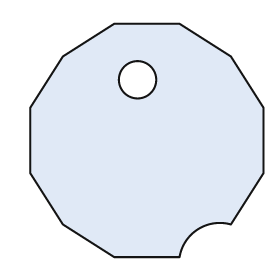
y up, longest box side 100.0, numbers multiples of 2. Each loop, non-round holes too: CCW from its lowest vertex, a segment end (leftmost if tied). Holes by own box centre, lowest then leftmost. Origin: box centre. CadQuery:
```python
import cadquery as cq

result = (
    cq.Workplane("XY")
    .moveTo(-14.0, -50.0)
    .lineTo(14.0, -50.0)
    .threePointArc((22.0, -38.0), (36.0, -36.0))
    .lineTo(50.0, -14.0)
    .lineTo(50.0, 14.0)
    .lineTo(36.0, 36.0)
    .lineTo(14.0, 50.0)
    .lineTo(-14.0, 50.0)
    .lineTo(-36.0, 36.0)
    .lineTo(-50.0, 14.0)
    .lineTo(-50.0, -14.0)
    .lineTo(-36.0, -36.0)
    .close()
    .moveTo(-4.0, 26.0)
    .circle(8.0)
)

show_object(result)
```